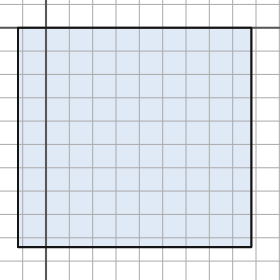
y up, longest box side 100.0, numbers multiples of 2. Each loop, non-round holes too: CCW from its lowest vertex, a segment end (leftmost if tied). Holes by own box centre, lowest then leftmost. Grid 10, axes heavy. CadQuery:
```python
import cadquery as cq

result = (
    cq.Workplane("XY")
    .moveTo(-12.0, -94.0)
    .lineTo(88.0, -94.0)
    .lineTo(88.0, 0.0)
    .lineTo(-12.0, 0.0)
    .close()
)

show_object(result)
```